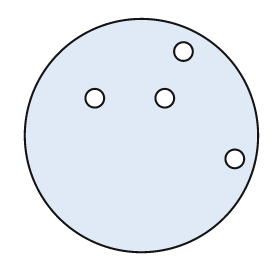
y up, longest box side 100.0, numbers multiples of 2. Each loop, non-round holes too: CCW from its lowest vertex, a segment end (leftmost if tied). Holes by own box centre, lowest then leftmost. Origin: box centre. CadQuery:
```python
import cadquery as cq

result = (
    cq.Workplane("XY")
    .moveTo(0.0, 0.0)
    .circle(50.0)
    .moveTo(40.0, -10.0)
    .circle(4.0)
    .moveTo(-20.0, 16.0)
    .circle(4.0)
    .moveTo(10.0, 16.0)
    .circle(4.0)
    .moveTo(18.0, 36.0)
    .circle(4.0)
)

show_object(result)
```